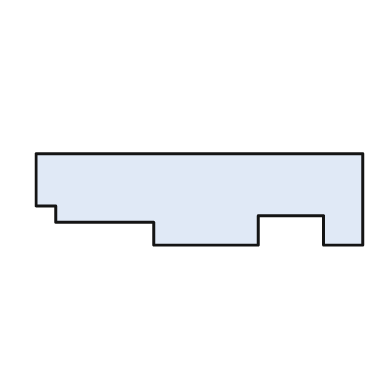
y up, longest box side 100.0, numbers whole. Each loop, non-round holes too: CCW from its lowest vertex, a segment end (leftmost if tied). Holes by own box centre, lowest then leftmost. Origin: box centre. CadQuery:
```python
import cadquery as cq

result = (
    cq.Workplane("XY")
    .moveTo(-14.0, -14.0)
    .lineTo(18.0, -14.0)
    .lineTo(18.0, -5.0)
    .lineTo(38.0, -5.0)
    .lineTo(38.0, -14.0)
    .lineTo(50.0, -14.0)
    .lineTo(50.0, 14.0)
    .lineTo(-50.0, 14.0)
    .lineTo(-50.0, -2.0)
    .lineTo(-44.0, -2.0)
    .lineTo(-44.0, -7.0)
    .lineTo(-14.0, -7.0)
    .close()
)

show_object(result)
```